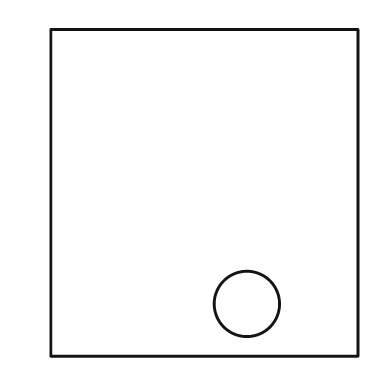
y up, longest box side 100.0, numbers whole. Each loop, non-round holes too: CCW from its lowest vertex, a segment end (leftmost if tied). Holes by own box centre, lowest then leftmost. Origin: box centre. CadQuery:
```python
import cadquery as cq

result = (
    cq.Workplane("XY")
    .moveTo(-47.0, -50.0)
    .lineTo(47.0, -50.0)
    .lineTo(47.0, 50.0)
    .lineTo(-47.0, 50.0)
    .close()
    .moveTo(13.0, -34.0)
    .circle(10.0)
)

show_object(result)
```